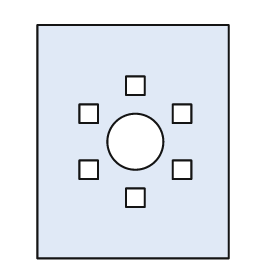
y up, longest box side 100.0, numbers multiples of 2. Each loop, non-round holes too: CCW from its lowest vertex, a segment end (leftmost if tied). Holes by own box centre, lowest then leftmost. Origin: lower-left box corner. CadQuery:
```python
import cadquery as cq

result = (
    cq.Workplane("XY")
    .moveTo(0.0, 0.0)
    .lineTo(82.0, 0.0)
    .lineTo(82.0, 100.0)
    .lineTo(0.0, 100.0)
    .close()
    .moveTo(38.0, 22.0)
    .lineTo(46.0, 22.0)
    .lineTo(46.0, 30.0)
    .lineTo(38.0, 30.0)
    .close()
    .moveTo(18.0, 34.0)
    .lineTo(26.0, 34.0)
    .lineTo(26.0, 42.0)
    .lineTo(18.0, 42.0)
    .close()
    .moveTo(58.0, 34.0)
    .lineTo(66.0, 34.0)
    .lineTo(66.0, 42.0)
    .lineTo(58.0, 42.0)
    .close()
    .moveTo(42.0, 50.0)
    .circle(12.0)
    .moveTo(18.0, 58.0)
    .lineTo(26.0, 58.0)
    .lineTo(26.0, 66.0)
    .lineTo(18.0, 66.0)
    .close()
    .moveTo(58.0, 58.0)
    .lineTo(66.0, 58.0)
    .lineTo(66.0, 66.0)
    .lineTo(58.0, 66.0)
    .close()
    .moveTo(38.0, 70.0)
    .lineTo(46.0, 70.0)
    .lineTo(46.0, 78.0)
    .lineTo(38.0, 78.0)
    .close()
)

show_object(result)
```